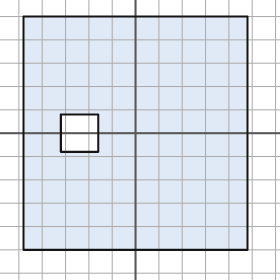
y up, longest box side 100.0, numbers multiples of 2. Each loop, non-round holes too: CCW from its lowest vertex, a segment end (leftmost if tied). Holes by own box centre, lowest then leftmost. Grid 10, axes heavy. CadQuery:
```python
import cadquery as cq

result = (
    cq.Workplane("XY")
    .moveTo(-48.0, -50.0)
    .lineTo(48.0, -50.0)
    .lineTo(48.0, 50.0)
    .lineTo(-48.0, 50.0)
    .close()
    .moveTo(-32.0, -8.0)
    .lineTo(-16.0, -8.0)
    .lineTo(-16.0, 8.0)
    .lineTo(-32.0, 8.0)
    .close()
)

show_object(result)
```